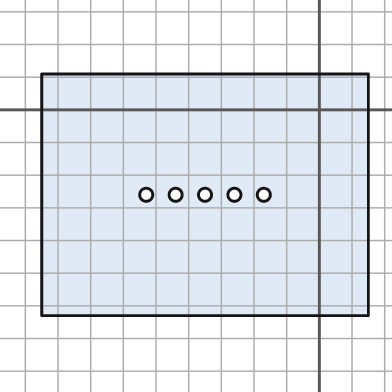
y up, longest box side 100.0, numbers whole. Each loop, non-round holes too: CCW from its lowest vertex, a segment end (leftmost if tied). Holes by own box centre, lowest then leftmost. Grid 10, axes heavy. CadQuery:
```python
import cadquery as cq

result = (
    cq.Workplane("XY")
    .moveTo(-85.0, -63.0)
    .lineTo(15.0, -63.0)
    .lineTo(15.0, 11.0)
    .lineTo(-85.0, 11.0)
    .close()
    .moveTo(-53.0, -26.0)
    .circle(2.0)
    .moveTo(-44.0, -26.0)
    .circle(2.0)
    .moveTo(-35.0, -26.0)
    .circle(2.0)
    .moveTo(-26.0, -26.0)
    .circle(2.0)
    .moveTo(-17.0, -26.0)
    .circle(2.0)
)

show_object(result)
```